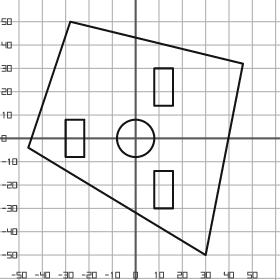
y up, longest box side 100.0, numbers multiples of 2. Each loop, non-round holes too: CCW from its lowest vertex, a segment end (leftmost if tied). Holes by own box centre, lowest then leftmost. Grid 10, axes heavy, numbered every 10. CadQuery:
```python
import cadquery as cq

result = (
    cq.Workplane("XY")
    .moveTo(30.0, -50.0)
    .lineTo(46.0, 32.0)
    .lineTo(-28.0, 50.0)
    .lineTo(-46.0, -4.0)
    .close()
    .moveTo(8.0, -30.0)
    .lineTo(16.0, -30.0)
    .lineTo(16.0, -14.0)
    .lineTo(8.0, -14.0)
    .close()
    .moveTo(-30.0, -8.0)
    .lineTo(-22.0, -8.0)
    .lineTo(-22.0, 8.0)
    .lineTo(-30.0, 8.0)
    .close()
    .moveTo(0.0, 0.0)
    .circle(8.0)
    .moveTo(8.0, 14.0)
    .lineTo(16.0, 14.0)
    .lineTo(16.0, 30.0)
    .lineTo(8.0, 30.0)
    .close()
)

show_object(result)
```